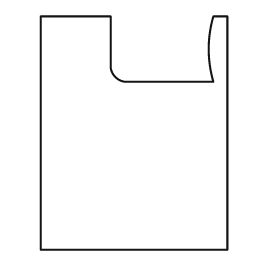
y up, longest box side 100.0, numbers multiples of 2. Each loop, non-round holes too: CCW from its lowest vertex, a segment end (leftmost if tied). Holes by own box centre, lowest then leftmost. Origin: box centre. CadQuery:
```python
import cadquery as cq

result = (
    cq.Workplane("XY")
    .moveTo(-40.0, -50.0)
    .lineTo(40.0, -50.0)
    .lineTo(40.0, 50.0)
    .lineTo(34.0, 50.0)
    .threePointArc((32.0, 36.0), (34.0, 22.0))
    .lineTo(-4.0, 22.0)
    .threePointArc((-8.0, 24.0), (-10.0, 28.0))
    .lineTo(-10.0, 50.0)
    .lineTo(-40.0, 50.0)
    .close()
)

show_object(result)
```